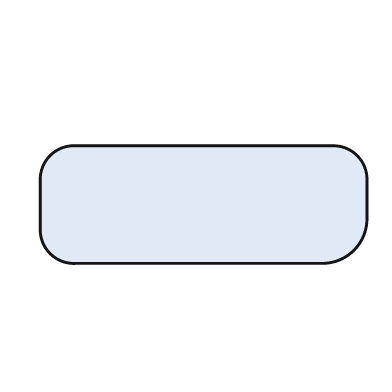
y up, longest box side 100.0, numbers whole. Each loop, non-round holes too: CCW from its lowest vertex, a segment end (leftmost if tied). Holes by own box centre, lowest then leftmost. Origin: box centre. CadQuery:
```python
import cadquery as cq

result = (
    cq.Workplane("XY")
    .moveTo(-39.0, -18.0)
    .lineTo(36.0, -18.0)
    .threePointArc((46.0, -14.0), (50.0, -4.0))
    .lineTo(50.0, 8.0)
    .threePointArc((47.0, 15.0), (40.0, 18.0))
    .lineTo(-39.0, 18.0)
    .threePointArc((-47.0, 15.0), (-50.0, 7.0))
    .lineTo(-50.0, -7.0)
    .threePointArc((-47.0, -15.0), (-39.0, -18.0))
    .close()
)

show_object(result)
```